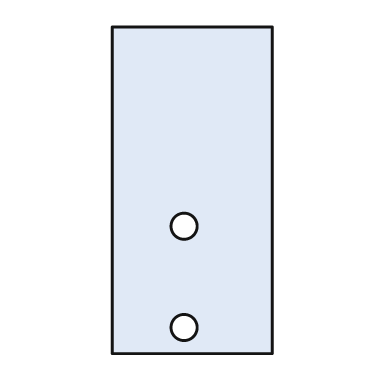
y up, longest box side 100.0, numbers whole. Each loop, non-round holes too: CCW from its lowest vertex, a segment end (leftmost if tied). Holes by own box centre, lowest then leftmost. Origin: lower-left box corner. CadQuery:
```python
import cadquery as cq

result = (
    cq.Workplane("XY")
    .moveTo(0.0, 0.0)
    .lineTo(49.0, 0.0)
    .lineTo(49.0, 100.0)
    .lineTo(0.0, 100.0)
    .close()
    .moveTo(22.0, 8.0)
    .circle(4.0)
    .moveTo(22.0, 39.0)
    .circle(4.0)
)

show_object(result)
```